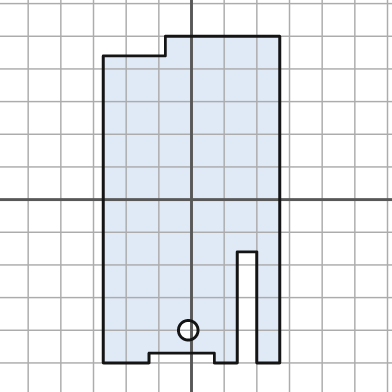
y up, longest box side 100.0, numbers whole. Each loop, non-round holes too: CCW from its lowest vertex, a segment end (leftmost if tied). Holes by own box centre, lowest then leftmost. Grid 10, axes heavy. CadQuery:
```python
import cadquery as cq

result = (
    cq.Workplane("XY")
    .moveTo(-27.0, -50.0)
    .lineTo(-13.0, -50.0)
    .lineTo(-13.0, -47.0)
    .lineTo(7.0, -47.0)
    .lineTo(7.0, -50.0)
    .lineTo(14.0, -50.0)
    .lineTo(14.0, -16.0)
    .lineTo(20.0, -16.0)
    .lineTo(20.0, -50.0)
    .lineTo(27.0, -50.0)
    .lineTo(27.0, 50.0)
    .lineTo(-8.0, 50.0)
    .lineTo(-8.0, 44.0)
    .lineTo(-27.0, 44.0)
    .close()
    .moveTo(-1.0, -40.0)
    .circle(3.0)
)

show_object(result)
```